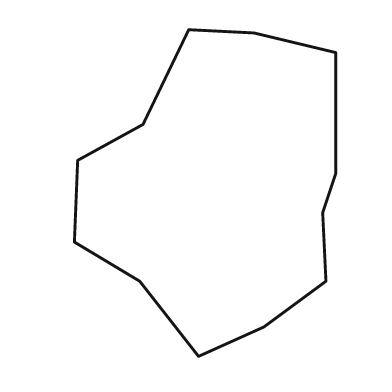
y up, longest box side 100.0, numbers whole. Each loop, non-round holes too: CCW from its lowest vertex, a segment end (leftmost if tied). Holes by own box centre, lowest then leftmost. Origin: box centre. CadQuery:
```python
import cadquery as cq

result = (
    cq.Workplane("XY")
    .moveTo(-2.0, -50.0)
    .lineTo(18.0, -41.0)
    .lineTo(37.0, -27.0)
    .lineTo(36.0, -6.0)
    .lineTo(40.0, 6.0)
    .lineTo(40.0, 43.0)
    .lineTo(15.0, 49.0)
    .lineTo(-5.0, 50.0)
    .lineTo(-19.0, 21.0)
    .lineTo(-39.0, 10.0)
    .lineTo(-40.0, -15.0)
    .lineTo(-20.0, -27.0)
    .close()
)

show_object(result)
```